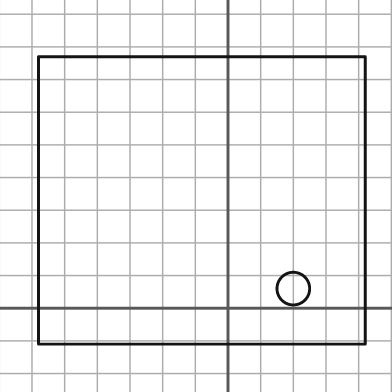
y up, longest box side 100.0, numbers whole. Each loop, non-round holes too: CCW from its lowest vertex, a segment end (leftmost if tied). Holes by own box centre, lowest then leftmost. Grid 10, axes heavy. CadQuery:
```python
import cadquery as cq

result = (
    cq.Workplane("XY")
    .moveTo(-58.0, -11.0)
    .lineTo(42.0, -11.0)
    .lineTo(42.0, 77.0)
    .lineTo(-58.0, 77.0)
    .close()
    .moveTo(20.0, 6.0)
    .circle(5.0)
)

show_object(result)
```